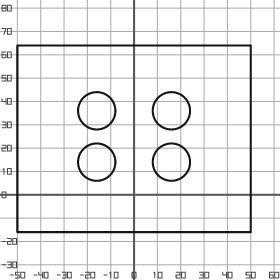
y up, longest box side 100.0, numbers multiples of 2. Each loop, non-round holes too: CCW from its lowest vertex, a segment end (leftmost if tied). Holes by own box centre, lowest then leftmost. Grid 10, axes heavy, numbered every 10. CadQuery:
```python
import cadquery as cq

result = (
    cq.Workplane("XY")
    .moveTo(-50.0, -16.0)
    .lineTo(50.0, -16.0)
    .lineTo(50.0, 64.0)
    .lineTo(-50.0, 64.0)
    .close()
    .moveTo(-16.0, 14.0)
    .circle(8.0)
    .moveTo(16.0, 14.0)
    .circle(8.0)
    .moveTo(-16.0, 36.0)
    .circle(8.0)
    .moveTo(16.0, 36.0)
    .circle(8.0)
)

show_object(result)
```